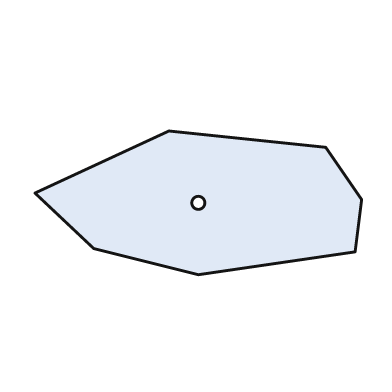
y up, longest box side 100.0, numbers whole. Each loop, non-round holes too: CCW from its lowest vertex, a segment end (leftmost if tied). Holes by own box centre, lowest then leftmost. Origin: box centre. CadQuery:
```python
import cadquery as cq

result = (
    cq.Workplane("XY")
    .moveTo(0.0, -22.0)
    .lineTo(48.0, -15.0)
    .lineTo(50.0, 1.0)
    .lineTo(39.0, 17.0)
    .lineTo(-9.0, 22.0)
    .lineTo(-50.0, 3.0)
    .lineTo(-32.0, -14.0)
    .close()
    .moveTo(0.0, 0.0)
    .circle(2.0)
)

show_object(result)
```